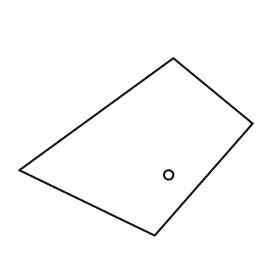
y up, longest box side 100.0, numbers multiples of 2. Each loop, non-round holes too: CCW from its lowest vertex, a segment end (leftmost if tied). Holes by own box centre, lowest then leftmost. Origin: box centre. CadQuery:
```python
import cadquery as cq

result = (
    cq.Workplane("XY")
    .moveTo(8.0, -38.0)
    .lineTo(50.0, 10.0)
    .lineTo(16.0, 38.0)
    .lineTo(-50.0, -10.0)
    .close()
    .moveTo(14.0, -12.0)
    .circle(2.0)
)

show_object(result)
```